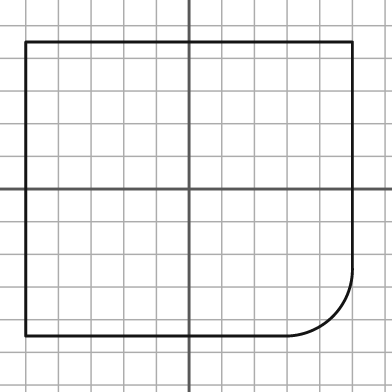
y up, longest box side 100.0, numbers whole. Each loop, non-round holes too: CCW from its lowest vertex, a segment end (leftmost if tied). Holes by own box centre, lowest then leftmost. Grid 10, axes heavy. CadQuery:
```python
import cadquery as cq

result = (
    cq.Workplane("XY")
    .moveTo(-50.0, -45.0)
    .lineTo(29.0, -45.0)
    .threePointArc((44.0, -39.0), (50.0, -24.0))
    .lineTo(50.0, 45.0)
    .lineTo(-50.0, 45.0)
    .close()
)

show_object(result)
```